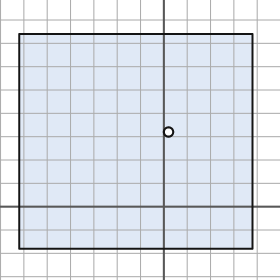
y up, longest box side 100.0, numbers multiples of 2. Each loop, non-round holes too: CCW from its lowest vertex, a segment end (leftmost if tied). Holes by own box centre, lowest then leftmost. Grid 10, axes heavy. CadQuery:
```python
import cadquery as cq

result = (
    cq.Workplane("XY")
    .moveTo(-62.0, -18.0)
    .lineTo(38.0, -18.0)
    .lineTo(38.0, 74.0)
    .lineTo(-62.0, 74.0)
    .close()
    .moveTo(2.0, 32.0)
    .circle(2.0)
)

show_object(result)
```